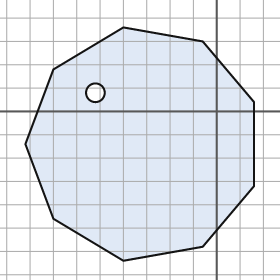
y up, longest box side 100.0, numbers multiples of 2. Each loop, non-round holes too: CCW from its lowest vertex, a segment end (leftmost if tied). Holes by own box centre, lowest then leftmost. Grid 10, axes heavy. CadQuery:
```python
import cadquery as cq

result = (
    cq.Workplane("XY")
    .moveTo(-40.0, -64.0)
    .lineTo(-6.0, -58.0)
    .lineTo(16.0, -32.0)
    .lineTo(16.0, 4.0)
    .lineTo(-6.0, 30.0)
    .lineTo(-40.0, 36.0)
    .lineTo(-70.0, 18.0)
    .lineTo(-82.0, -14.0)
    .lineTo(-70.0, -46.0)
    .close()
    .moveTo(-52.0, 8.0)
    .circle(4.0)
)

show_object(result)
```